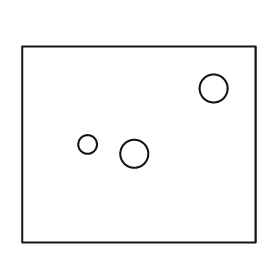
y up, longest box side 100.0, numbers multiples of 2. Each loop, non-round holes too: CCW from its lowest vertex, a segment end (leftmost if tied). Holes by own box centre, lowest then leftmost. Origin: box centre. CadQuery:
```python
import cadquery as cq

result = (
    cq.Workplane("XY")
    .moveTo(-50.0, -42.0)
    .lineTo(50.0, -42.0)
    .lineTo(50.0, 42.0)
    .lineTo(-50.0, 42.0)
    .close()
    .moveTo(-2.0, -4.0)
    .circle(6.0)
    .moveTo(-22.0, 0.0)
    .circle(4.0)
    .moveTo(32.0, 24.0)
    .circle(6.0)
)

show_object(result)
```